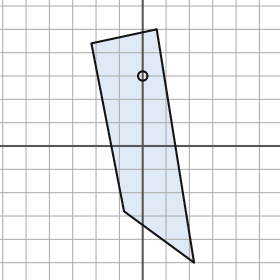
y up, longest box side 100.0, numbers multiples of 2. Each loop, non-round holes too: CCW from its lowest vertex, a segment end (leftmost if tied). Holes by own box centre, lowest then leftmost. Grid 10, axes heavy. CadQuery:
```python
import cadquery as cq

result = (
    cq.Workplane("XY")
    .moveTo(22.0, -50.0)
    .lineTo(6.0, 50.0)
    .lineTo(-22.0, 44.0)
    .lineTo(-8.0, -28.0)
    .close()
    .moveTo(0.0, 30.0)
    .circle(2.0)
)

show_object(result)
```